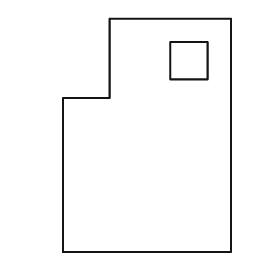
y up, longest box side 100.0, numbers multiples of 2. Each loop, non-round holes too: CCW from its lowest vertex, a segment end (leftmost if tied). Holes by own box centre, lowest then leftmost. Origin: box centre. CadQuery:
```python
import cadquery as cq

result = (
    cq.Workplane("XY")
    .moveTo(-36.0, -50.0)
    .lineTo(36.0, -50.0)
    .lineTo(36.0, 50.0)
    .lineTo(-16.0, 50.0)
    .lineTo(-16.0, 16.0)
    .lineTo(-36.0, 16.0)
    .close()
    .moveTo(10.0, 24.0)
    .lineTo(26.0, 24.0)
    .lineTo(26.0, 40.0)
    .lineTo(10.0, 40.0)
    .close()
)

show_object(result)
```